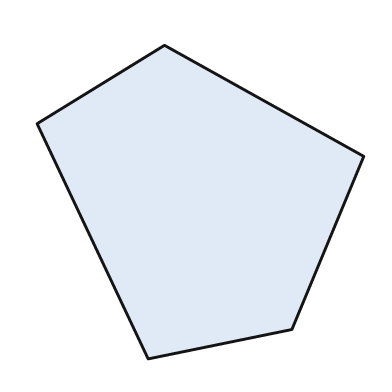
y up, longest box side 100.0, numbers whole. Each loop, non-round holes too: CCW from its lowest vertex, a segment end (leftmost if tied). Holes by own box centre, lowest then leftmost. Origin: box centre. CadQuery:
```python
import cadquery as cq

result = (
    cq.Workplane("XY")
    .moveTo(-16.0, -48.0)
    .lineTo(28.0, -39.0)
    .lineTo(50.0, 14.0)
    .lineTo(-11.0, 48.0)
    .lineTo(-50.0, 24.0)
    .close()
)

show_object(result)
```